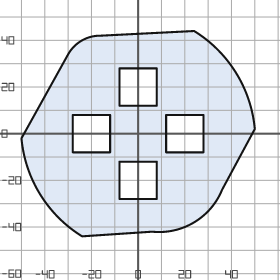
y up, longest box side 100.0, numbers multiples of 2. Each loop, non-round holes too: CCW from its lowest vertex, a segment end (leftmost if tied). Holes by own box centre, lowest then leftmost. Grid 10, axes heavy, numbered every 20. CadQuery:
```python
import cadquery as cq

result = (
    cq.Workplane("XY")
    .moveTo(-24.0, -44.0)
    .lineTo(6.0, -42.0)
    .threePointArc((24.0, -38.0), (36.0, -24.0))
    .lineTo(50.0, 2.0)
    .threePointArc((42.0, 26.0), (24.0, 44.0))
    .lineTo(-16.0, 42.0)
    .threePointArc((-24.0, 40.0), (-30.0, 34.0))
    .lineTo(-50.0, -2.0)
    .threePointArc((-42.0, -26.0), (-24.0, -44.0))
    .close()
    .moveTo(-8.0, -28.0)
    .lineTo(8.0, -28.0)
    .lineTo(8.0, -12.0)
    .lineTo(-8.0, -12.0)
    .close()
    .moveTo(-28.0, -8.0)
    .lineTo(-12.0, -8.0)
    .lineTo(-12.0, 8.0)
    .lineTo(-28.0, 8.0)
    .close()
    .moveTo(12.0, -8.0)
    .lineTo(28.0, -8.0)
    .lineTo(28.0, 8.0)
    .lineTo(12.0, 8.0)
    .close()
    .moveTo(-8.0, 12.0)
    .lineTo(8.0, 12.0)
    .lineTo(8.0, 28.0)
    .lineTo(-8.0, 28.0)
    .close()
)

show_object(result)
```